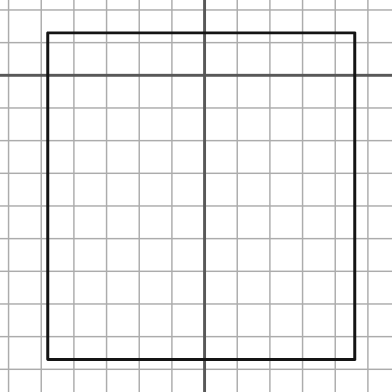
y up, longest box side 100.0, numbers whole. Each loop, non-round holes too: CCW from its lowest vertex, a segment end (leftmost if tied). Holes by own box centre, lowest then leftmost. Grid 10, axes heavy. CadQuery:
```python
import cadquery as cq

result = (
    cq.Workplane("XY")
    .moveTo(-48.0, -87.0)
    .lineTo(46.0, -87.0)
    .lineTo(46.0, 13.0)
    .lineTo(-48.0, 13.0)
    .close()
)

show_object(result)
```